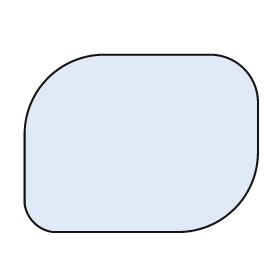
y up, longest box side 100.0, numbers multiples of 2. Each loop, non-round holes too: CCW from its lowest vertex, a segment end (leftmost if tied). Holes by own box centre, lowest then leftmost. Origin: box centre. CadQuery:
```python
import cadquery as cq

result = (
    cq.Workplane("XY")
    .moveTo(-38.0, -38.0)
    .lineTo(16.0, -38.0)
    .threePointArc((40.0, -28.0), (50.0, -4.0))
    .lineTo(50.0, 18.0)
    .threePointArc((44.0, 32.0), (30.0, 38.0))
    .lineTo(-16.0, 38.0)
    .threePointArc((-40.0, 28.0), (-50.0, 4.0))
    .lineTo(-50.0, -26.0)
    .threePointArc((-46.0, -34.0), (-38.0, -38.0))
    .close()
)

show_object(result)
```